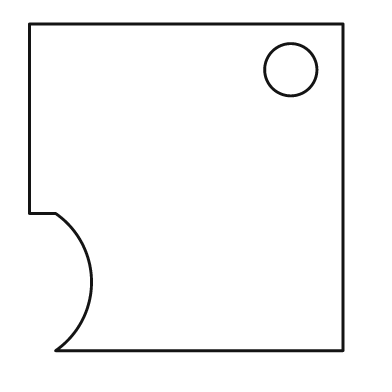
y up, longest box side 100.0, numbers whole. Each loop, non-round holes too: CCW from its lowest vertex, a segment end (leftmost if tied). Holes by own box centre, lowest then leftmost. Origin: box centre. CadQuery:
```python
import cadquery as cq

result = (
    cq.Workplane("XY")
    .moveTo(-40.0, -50.0)
    .lineTo(48.0, -50.0)
    .lineTo(48.0, 50.0)
    .lineTo(-48.0, 50.0)
    .lineTo(-48.0, -8.0)
    .lineTo(-40.0, -8.0)
    .threePointArc((-29.0, -29.0), (-40.0, -50.0))
    .close()
    .moveTo(32.0, 36.0)
    .circle(8.0)
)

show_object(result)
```